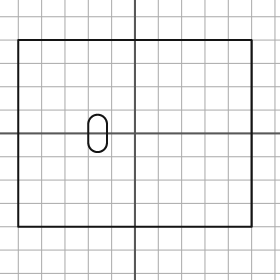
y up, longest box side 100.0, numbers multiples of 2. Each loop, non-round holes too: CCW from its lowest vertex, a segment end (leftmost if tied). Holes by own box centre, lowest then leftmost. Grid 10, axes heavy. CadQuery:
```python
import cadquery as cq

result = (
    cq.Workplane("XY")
    .moveTo(-50.0, -40.0)
    .lineTo(50.0, -40.0)
    .lineTo(50.0, 40.0)
    .lineTo(-50.0, 40.0)
    .close()
    .moveTo(-20.0, -4.0)
    .threePointArc((-16.0, -8.0), (-12.0, -4.0))
    .lineTo(-12.0, 4.0)
    .threePointArc((-16.0, 8.0), (-20.0, 4.0))
    .close()
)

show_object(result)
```